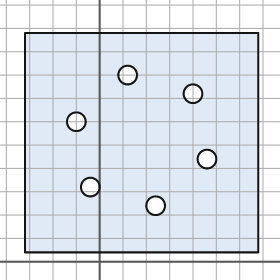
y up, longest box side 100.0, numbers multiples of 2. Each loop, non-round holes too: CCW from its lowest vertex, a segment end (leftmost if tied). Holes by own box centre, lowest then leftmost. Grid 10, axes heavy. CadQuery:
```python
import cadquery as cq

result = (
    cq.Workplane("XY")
    .moveTo(-32.0, 4.0)
    .lineTo(68.0, 4.0)
    .lineTo(68.0, 98.0)
    .lineTo(-32.0, 98.0)
    .close()
    .moveTo(24.0, 24.0)
    .circle(4.0)
    .moveTo(-4.0, 32.0)
    .circle(4.0)
    .moveTo(46.0, 44.0)
    .circle(4.0)
    .moveTo(-10.0, 60.0)
    .circle(4.0)
    .moveTo(40.0, 72.0)
    .circle(4.0)
    .moveTo(12.0, 80.0)
    .circle(4.0)
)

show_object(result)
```